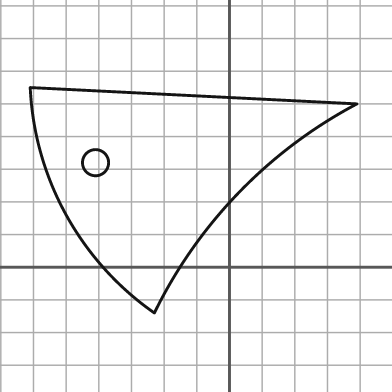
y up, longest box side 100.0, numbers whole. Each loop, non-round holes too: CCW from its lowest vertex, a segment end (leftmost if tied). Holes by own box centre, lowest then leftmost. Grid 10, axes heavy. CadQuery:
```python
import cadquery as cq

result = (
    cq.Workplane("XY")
    .moveTo(-23.0, -14.0)
    .threePointArc((3.0, 23.0), (39.0, 50.0))
    .lineTo(-61.0, 55.0)
    .threePointArc((-50.0, 16.0), (-23.0, -14.0))
    .close()
    .moveTo(-41.0, 32.0)
    .circle(4.0)
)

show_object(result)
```